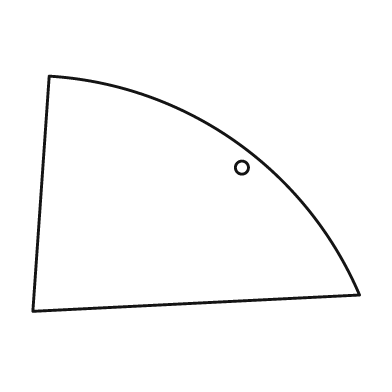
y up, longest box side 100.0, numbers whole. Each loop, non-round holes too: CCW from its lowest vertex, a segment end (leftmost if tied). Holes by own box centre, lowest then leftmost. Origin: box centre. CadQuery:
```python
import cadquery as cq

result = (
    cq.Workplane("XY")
    .moveTo(-50.0, -36.0)
    .lineTo(50.0, -31.0)
    .threePointArc((12.0, 16.0), (-45.0, 36.0))
    .close()
    .moveTo(14.0, 8.0)
    .circle(2.0)
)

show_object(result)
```